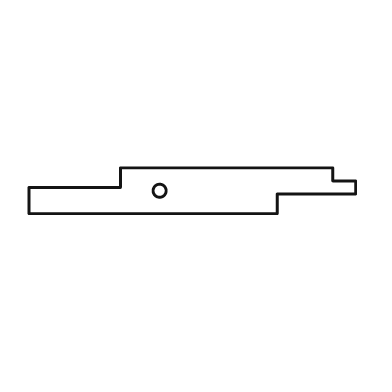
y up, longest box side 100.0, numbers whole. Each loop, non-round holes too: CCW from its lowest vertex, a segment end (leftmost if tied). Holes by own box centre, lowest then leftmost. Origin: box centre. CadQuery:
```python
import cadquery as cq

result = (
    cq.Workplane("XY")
    .moveTo(-50.0, -7.0)
    .lineTo(26.0, -7.0)
    .lineTo(26.0, -1.0)
    .lineTo(50.0, -1.0)
    .lineTo(50.0, 3.0)
    .lineTo(43.0, 3.0)
    .lineTo(43.0, 7.0)
    .lineTo(-22.0, 7.0)
    .lineTo(-22.0, 1.0)
    .lineTo(-50.0, 1.0)
    .close()
    .moveTo(-10.0, 0.0)
    .circle(2.0)
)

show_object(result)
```